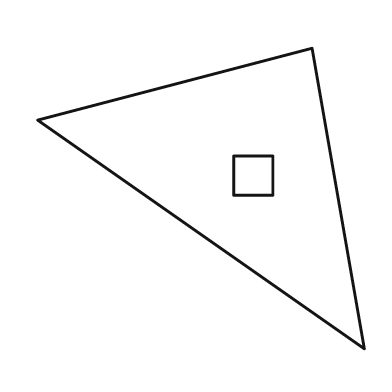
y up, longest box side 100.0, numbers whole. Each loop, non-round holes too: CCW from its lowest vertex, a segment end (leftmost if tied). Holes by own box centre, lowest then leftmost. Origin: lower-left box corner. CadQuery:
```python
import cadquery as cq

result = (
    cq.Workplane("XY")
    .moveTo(100.0, 0.0)
    .lineTo(84.0, 92.0)
    .lineTo(0.0, 70.0)
    .close()
    .moveTo(60.0, 47.0)
    .lineTo(72.0, 47.0)
    .lineTo(72.0, 59.0)
    .lineTo(60.0, 59.0)
    .close()
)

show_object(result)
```